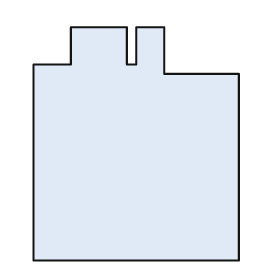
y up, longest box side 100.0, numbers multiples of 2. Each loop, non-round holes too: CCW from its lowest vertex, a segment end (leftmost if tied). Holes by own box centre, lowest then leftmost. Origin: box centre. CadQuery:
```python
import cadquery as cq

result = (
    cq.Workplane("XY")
    .moveTo(-44.0, -50.0)
    .lineTo(44.0, -50.0)
    .lineTo(44.0, 30.0)
    .lineTo(12.0, 30.0)
    .lineTo(12.0, 50.0)
    .lineTo(0.0, 50.0)
    .lineTo(0.0, 34.0)
    .lineTo(-4.0, 34.0)
    .lineTo(-4.0, 50.0)
    .lineTo(-28.0, 50.0)
    .lineTo(-28.0, 34.0)
    .lineTo(-44.0, 34.0)
    .close()
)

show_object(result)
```